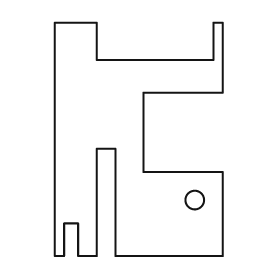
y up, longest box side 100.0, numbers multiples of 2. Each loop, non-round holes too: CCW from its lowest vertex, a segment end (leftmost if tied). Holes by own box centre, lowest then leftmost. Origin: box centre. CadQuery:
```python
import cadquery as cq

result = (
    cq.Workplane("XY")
    .moveTo(-36.0, -50.0)
    .lineTo(-32.0, -50.0)
    .lineTo(-32.0, -36.0)
    .lineTo(-26.0, -36.0)
    .lineTo(-26.0, -50.0)
    .lineTo(-18.0, -50.0)
    .lineTo(-18.0, -4.0)
    .lineTo(-10.0, -4.0)
    .lineTo(-10.0, -50.0)
    .lineTo(36.0, -50.0)
    .lineTo(36.0, -14.0)
    .lineTo(2.0, -14.0)
    .lineTo(2.0, 20.0)
    .lineTo(36.0, 20.0)
    .lineTo(36.0, 50.0)
    .lineTo(32.0, 50.0)
    .lineTo(32.0, 34.0)
    .lineTo(-18.0, 34.0)
    .lineTo(-18.0, 50.0)
    .lineTo(-36.0, 50.0)
    .close()
    .moveTo(24.0, -26.0)
    .circle(4.0)
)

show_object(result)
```